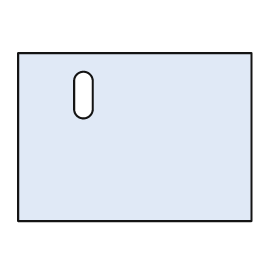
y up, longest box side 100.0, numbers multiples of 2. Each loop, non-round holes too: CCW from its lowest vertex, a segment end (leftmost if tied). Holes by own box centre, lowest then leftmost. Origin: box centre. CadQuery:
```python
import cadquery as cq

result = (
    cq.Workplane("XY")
    .moveTo(-50.0, -36.0)
    .lineTo(50.0, -36.0)
    .lineTo(50.0, 36.0)
    .lineTo(-50.0, 36.0)
    .close()
    .moveTo(-26.0, 12.0)
    .threePointArc((-22.0, 8.0), (-18.0, 12.0))
    .lineTo(-18.0, 24.0)
    .threePointArc((-22.0, 28.0), (-26.0, 24.0))
    .close()
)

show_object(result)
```